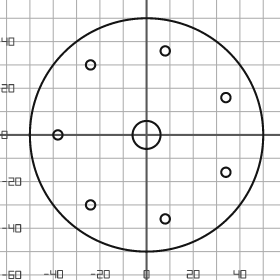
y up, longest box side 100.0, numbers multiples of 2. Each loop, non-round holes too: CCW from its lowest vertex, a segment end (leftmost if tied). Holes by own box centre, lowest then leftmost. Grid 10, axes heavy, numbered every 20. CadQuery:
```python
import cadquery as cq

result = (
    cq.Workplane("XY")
    .moveTo(0.0, 0.0)
    .circle(50.0)
    .moveTo(8.0, -36.0)
    .circle(2.0)
    .moveTo(-24.0, -30.0)
    .circle(2.0)
    .moveTo(34.0, -16.0)
    .circle(2.0)
    .moveTo(-38.0, 0.0)
    .circle(2.0)
    .moveTo(0.0, 0.0)
    .circle(6.0)
    .moveTo(34.0, 16.0)
    .circle(2.0)
    .moveTo(-24.0, 30.0)
    .circle(2.0)
    .moveTo(8.0, 36.0)
    .circle(2.0)
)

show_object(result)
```